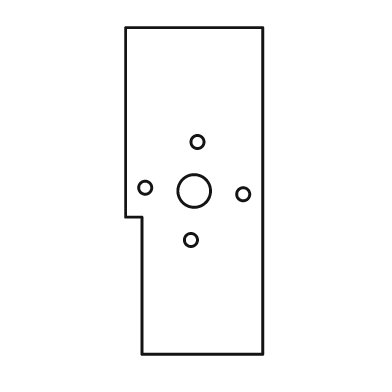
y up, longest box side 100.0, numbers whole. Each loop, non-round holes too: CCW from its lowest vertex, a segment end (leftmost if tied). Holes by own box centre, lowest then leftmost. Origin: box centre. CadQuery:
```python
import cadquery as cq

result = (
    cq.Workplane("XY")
    .moveTo(-16.0, -50.0)
    .lineTo(21.0, -50.0)
    .lineTo(21.0, 50.0)
    .lineTo(-21.0, 50.0)
    .lineTo(-21.0, -8.0)
    .lineTo(-16.0, -8.0)
    .close()
    .moveTo(-1.0, -15.0)
    .circle(2.0)
    .moveTo(15.0, -1.0)
    .circle(2.0)
    .moveTo(0.0, 0.0)
    .circle(5.0)
    .moveTo(-15.0, 1.0)
    .circle(2.0)
    .moveTo(1.0, 15.0)
    .circle(2.0)
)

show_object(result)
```